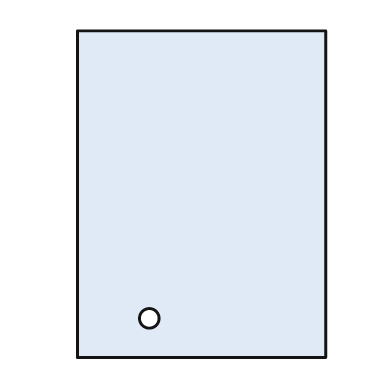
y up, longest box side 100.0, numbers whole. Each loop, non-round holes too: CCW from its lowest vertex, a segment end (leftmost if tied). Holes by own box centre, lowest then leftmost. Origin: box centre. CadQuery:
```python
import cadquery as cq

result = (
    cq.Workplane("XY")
    .moveTo(-38.0, -50.0)
    .lineTo(38.0, -50.0)
    .lineTo(38.0, 50.0)
    .lineTo(-38.0, 50.0)
    .close()
    .moveTo(-16.0, -38.0)
    .circle(3.0)
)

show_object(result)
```